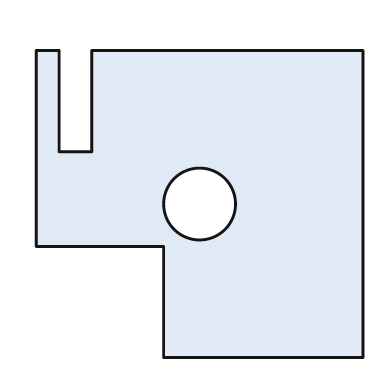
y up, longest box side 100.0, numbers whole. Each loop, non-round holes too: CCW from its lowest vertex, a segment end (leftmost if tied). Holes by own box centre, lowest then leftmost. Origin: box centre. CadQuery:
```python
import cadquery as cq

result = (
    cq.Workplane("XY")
    .moveTo(-11.0, -47.0)
    .lineTo(50.0, -47.0)
    .lineTo(50.0, 47.0)
    .lineTo(-33.0, 47.0)
    .lineTo(-33.0, 16.0)
    .lineTo(-43.0, 16.0)
    .lineTo(-43.0, 47.0)
    .lineTo(-50.0, 47.0)
    .lineTo(-50.0, -13.0)
    .lineTo(-11.0, -13.0)
    .close()
    .moveTo(0.0, 0.0)
    .circle(11.0)
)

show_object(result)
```